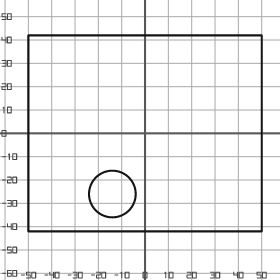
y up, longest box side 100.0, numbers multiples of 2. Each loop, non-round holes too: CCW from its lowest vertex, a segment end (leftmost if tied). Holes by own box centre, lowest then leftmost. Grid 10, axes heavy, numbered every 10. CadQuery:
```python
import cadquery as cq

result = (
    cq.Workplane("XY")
    .moveTo(-50.0, -42.0)
    .lineTo(50.0, -42.0)
    .lineTo(50.0, 42.0)
    .lineTo(-50.0, 42.0)
    .close()
    .moveTo(-14.0, -26.0)
    .circle(10.0)
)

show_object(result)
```